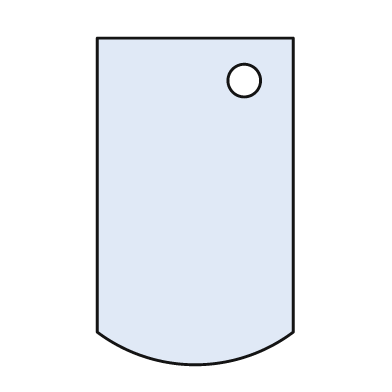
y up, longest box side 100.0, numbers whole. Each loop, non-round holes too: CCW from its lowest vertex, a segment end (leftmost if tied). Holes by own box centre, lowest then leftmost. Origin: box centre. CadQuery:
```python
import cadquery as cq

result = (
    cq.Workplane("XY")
    .moveTo(-30.0, -40.0)
    .threePointArc((0.0, -50.0), (30.0, -40.0))
    .lineTo(30.0, 50.0)
    .lineTo(-30.0, 50.0)
    .close()
    .moveTo(15.0, 37.0)
    .circle(5.0)
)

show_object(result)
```